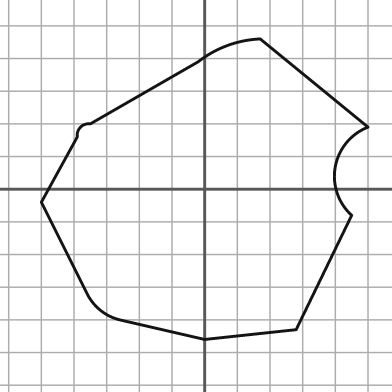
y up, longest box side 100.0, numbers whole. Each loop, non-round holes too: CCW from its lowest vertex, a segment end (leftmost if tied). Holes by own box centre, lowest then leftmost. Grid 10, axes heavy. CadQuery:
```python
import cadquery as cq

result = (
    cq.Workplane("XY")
    .moveTo(0.0, -46.0)
    .lineTo(28.0, -43.0)
    .lineTo(45.0, -8.0)
    .threePointArc((40.0, 7.0), (50.0, 19.0))
    .lineTo(17.0, 46.0)
    .threePointArc((7.0, 44.0), (-2.0, 39.0))
    .lineTo(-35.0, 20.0)
    .threePointArc((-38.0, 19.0), (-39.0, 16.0))
    .lineTo(-50.0, -4.0)
    .lineTo(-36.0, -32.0)
    .threePointArc((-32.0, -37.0), (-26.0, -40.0))
    .close()
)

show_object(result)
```